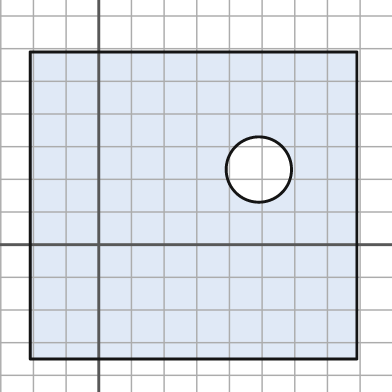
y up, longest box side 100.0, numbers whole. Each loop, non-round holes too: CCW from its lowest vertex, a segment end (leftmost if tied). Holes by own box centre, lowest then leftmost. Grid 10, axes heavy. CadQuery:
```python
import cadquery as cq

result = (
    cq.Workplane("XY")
    .moveTo(-21.0, -35.0)
    .lineTo(79.0, -35.0)
    .lineTo(79.0, 59.0)
    .lineTo(-21.0, 59.0)
    .close()
    .moveTo(49.0, 23.0)
    .circle(10.0)
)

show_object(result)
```